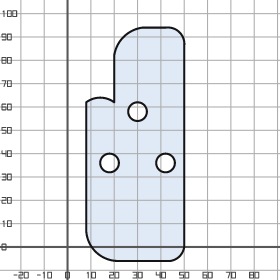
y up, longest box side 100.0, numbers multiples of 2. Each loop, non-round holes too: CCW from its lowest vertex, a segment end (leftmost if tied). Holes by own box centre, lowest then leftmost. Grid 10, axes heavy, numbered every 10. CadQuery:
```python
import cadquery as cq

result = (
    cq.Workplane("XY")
    .moveTo(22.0, -6.0)
    .lineTo(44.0, -6.0)
    .threePointArc((48.0, -4.0), (50.0, 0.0))
    .lineTo(50.0, 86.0)
    .threePointArc((48.0, 92.0), (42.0, 94.0))
    .lineTo(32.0, 94.0)
    .threePointArc((24.0, 90.0), (20.0, 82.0))
    .lineTo(20.0, 62.0)
    .threePointArc((14.0, 64.0), (8.0, 62.0))
    .lineTo(8.0, 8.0)
    .threePointArc((12.0, -2.0), (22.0, -6.0))
    .close()
    .moveTo(18.0, 36.0)
    .circle(4.0)
    .moveTo(42.0, 36.0)
    .circle(4.0)
    .moveTo(30.0, 58.0)
    .circle(4.0)
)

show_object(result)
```